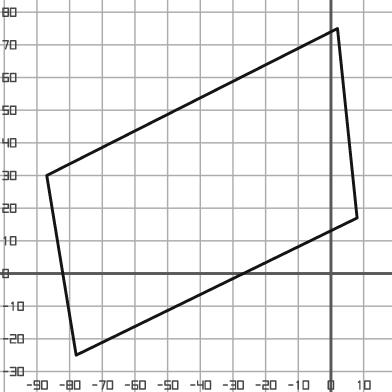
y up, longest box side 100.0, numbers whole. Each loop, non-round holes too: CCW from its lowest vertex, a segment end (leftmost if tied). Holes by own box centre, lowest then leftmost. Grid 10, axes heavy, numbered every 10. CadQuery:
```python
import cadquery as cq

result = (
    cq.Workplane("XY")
    .moveTo(-78.0, -25.0)
    .lineTo(8.0, 17.0)
    .lineTo(2.0, 75.0)
    .lineTo(-87.0, 30.0)
    .close()
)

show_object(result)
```